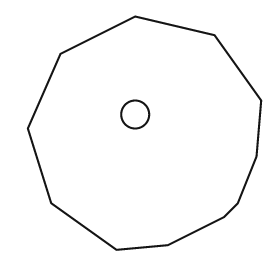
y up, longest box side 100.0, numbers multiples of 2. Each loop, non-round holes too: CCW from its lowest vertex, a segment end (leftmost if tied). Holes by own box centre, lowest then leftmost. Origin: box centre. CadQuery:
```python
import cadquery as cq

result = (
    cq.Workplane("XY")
    .moveTo(-12.0, -50.0)
    .lineTo(10.0, -48.0)
    .lineTo(34.0, -36.0)
    .lineTo(40.0, -30.0)
    .lineTo(48.0, -10.0)
    .lineTo(50.0, 14.0)
    .lineTo(30.0, 42.0)
    .lineTo(-4.0, 50.0)
    .lineTo(-36.0, 34.0)
    .lineTo(-50.0, 2.0)
    .lineTo(-40.0, -30.0)
    .close()
    .moveTo(-4.0, 8.0)
    .circle(6.0)
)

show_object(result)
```